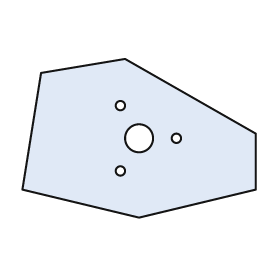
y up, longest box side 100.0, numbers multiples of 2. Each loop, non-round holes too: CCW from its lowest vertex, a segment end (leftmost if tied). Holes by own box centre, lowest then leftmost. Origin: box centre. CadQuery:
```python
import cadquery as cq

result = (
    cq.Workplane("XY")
    .moveTo(0.0, -34.0)
    .lineTo(50.0, -22.0)
    .lineTo(50.0, 2.0)
    .lineTo(-6.0, 34.0)
    .lineTo(-42.0, 28.0)
    .lineTo(-50.0, -22.0)
    .close()
    .moveTo(-8.0, -14.0)
    .circle(2.0)
    .moveTo(0.0, 0.0)
    .circle(6.0)
    .moveTo(16.0, 0.0)
    .circle(2.0)
    .moveTo(-8.0, 14.0)
    .circle(2.0)
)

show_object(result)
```